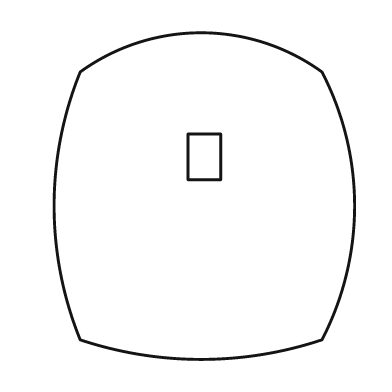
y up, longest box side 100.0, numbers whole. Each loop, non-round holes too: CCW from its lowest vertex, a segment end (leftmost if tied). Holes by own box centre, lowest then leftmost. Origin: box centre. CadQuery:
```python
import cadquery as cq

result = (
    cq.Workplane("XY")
    .moveTo(-38.0, -44.0)
    .threePointArc((-1.0, -50.0), (36.0, -44.0))
    .threePointArc((46.0, -3.0), (36.0, 38.0))
    .threePointArc((-1.0, 50.0), (-38.0, 38.0))
    .threePointArc((-46.0, -3.0), (-38.0, -44.0))
    .close()
    .moveTo(-5.0, 5.0)
    .lineTo(5.0, 5.0)
    .lineTo(5.0, 19.0)
    .lineTo(-5.0, 19.0)
    .close()
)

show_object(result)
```